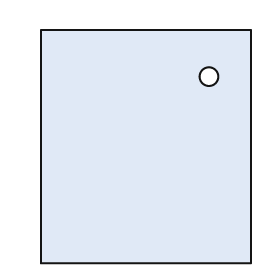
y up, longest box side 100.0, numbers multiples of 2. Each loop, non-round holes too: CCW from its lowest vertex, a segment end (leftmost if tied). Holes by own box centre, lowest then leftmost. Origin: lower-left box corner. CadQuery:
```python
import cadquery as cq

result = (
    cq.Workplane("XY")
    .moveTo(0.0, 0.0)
    .lineTo(90.0, 0.0)
    .lineTo(90.0, 100.0)
    .lineTo(0.0, 100.0)
    .close()
    .moveTo(72.0, 80.0)
    .circle(4.0)
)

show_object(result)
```